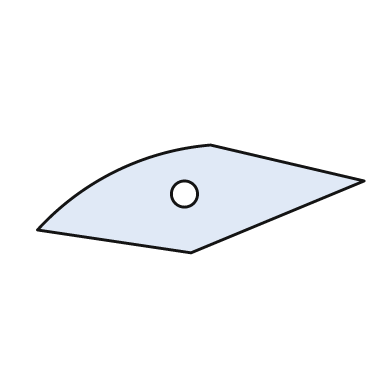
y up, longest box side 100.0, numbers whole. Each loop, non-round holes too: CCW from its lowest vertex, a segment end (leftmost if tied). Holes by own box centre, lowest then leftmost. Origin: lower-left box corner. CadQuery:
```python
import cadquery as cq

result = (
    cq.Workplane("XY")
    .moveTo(47.0, 0.0)
    .lineTo(100.0, 22.0)
    .lineTo(53.0, 33.0)
    .threePointArc((24.0, 25.0), (0.0, 7.0))
    .close()
    .moveTo(45.0, 18.0)
    .circle(4.0)
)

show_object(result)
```